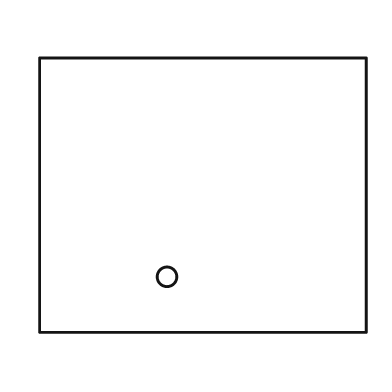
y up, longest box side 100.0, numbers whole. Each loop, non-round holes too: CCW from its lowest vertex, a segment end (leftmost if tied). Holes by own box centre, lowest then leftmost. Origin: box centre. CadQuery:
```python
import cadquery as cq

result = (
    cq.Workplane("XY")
    .moveTo(-50.0, -42.0)
    .lineTo(50.0, -42.0)
    .lineTo(50.0, 42.0)
    .lineTo(-50.0, 42.0)
    .close()
    .moveTo(-11.0, -25.0)
    .circle(3.0)
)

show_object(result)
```